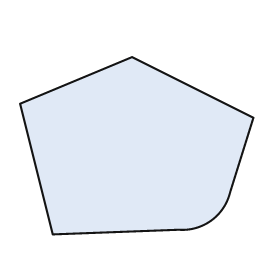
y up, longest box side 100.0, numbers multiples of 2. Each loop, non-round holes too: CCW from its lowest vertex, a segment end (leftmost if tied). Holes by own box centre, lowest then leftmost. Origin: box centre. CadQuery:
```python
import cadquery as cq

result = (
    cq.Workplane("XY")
    .moveTo(-36.0, -38.0)
    .lineTo(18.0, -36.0)
    .threePointArc((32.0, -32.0), (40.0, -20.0))
    .lineTo(50.0, 12.0)
    .lineTo(-2.0, 38.0)
    .lineTo(-50.0, 18.0)
    .close()
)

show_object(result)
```